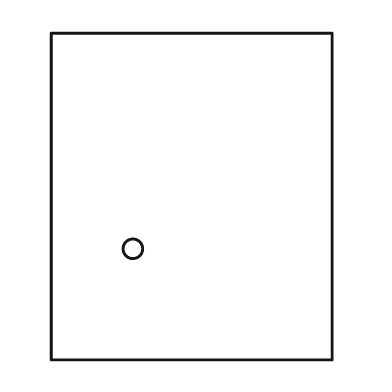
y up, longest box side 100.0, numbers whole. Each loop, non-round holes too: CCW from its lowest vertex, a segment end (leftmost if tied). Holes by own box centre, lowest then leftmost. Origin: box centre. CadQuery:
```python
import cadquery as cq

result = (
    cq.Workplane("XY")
    .moveTo(-43.0, -50.0)
    .lineTo(43.0, -50.0)
    .lineTo(43.0, 50.0)
    .lineTo(-43.0, 50.0)
    .close()
    .moveTo(-18.0, -16.0)
    .circle(3.0)
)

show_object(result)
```